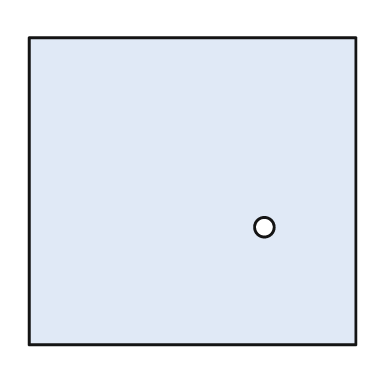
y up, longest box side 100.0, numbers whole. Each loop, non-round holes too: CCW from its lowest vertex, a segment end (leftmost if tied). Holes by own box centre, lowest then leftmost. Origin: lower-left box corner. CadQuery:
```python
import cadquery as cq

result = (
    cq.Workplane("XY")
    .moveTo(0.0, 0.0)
    .lineTo(100.0, 0.0)
    .lineTo(100.0, 94.0)
    .lineTo(0.0, 94.0)
    .close()
    .moveTo(72.0, 36.0)
    .circle(3.0)
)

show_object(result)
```